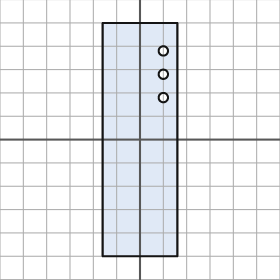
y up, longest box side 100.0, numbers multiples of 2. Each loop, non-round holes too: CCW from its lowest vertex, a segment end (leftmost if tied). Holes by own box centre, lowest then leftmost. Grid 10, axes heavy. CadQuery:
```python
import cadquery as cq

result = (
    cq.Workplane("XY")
    .moveTo(-16.0, -50.0)
    .lineTo(16.0, -50.0)
    .lineTo(16.0, 50.0)
    .lineTo(-16.0, 50.0)
    .close()
    .moveTo(10.0, 18.0)
    .circle(2.0)
    .moveTo(10.0, 28.0)
    .circle(2.0)
    .moveTo(10.0, 38.0)
    .circle(2.0)
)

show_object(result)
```